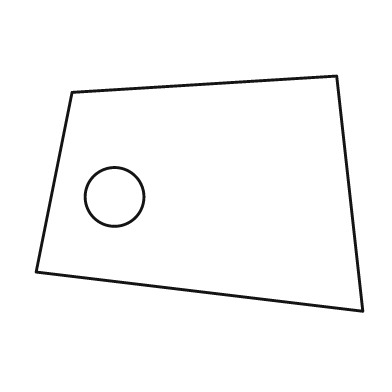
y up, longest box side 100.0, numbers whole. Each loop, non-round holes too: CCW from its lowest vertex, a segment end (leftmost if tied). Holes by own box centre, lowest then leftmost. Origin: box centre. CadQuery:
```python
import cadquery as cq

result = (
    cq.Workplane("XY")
    .moveTo(50.0, -36.0)
    .lineTo(42.0, 36.0)
    .lineTo(-39.0, 31.0)
    .lineTo(-50.0, -24.0)
    .close()
    .moveTo(-26.0, -1.0)
    .circle(9.0)
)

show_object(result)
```